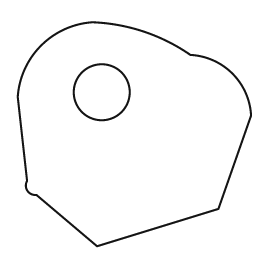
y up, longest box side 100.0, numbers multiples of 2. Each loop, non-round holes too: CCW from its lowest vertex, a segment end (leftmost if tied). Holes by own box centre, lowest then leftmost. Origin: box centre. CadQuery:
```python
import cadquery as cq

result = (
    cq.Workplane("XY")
    .moveTo(-16.0, -48.0)
    .lineTo(36.0, -32.0)
    .lineTo(50.0, 8.0)
    .threePointArc((42.0, 26.0), (24.0, 34.0))
    .threePointArc((4.0, 44.0), (-18.0, 48.0))
    .threePointArc((-40.0, 38.0), (-50.0, 16.0))
    .lineTo(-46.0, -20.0)
    .threePointArc((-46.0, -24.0), (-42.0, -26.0))
    .close()
    .moveTo(-14.0, 18.0)
    .circle(12.0)
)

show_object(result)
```